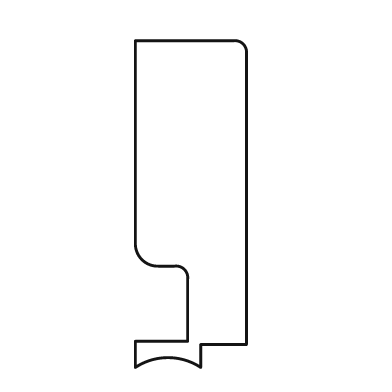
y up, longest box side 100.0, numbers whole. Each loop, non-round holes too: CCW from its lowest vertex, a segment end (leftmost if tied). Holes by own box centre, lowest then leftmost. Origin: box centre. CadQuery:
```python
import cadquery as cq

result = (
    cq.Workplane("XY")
    .moveTo(-17.0, -50.0)
    .threePointArc((-7.0, -47.0), (3.0, -50.0))
    .lineTo(3.0, -43.0)
    .lineTo(17.0, -43.0)
    .lineTo(17.0, 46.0)
    .threePointArc((16.0, 49.0), (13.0, 50.0))
    .lineTo(-17.0, 50.0)
    .lineTo(-17.0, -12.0)
    .threePointArc((-15.0, -17.0), (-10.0, -19.0))
    .lineTo(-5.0, -19.0)
    .threePointArc((-2.0, -20.0), (-1.0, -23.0))
    .lineTo(-1.0, -42.0)
    .lineTo(-17.0, -42.0)
    .close()
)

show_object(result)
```